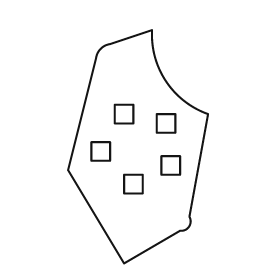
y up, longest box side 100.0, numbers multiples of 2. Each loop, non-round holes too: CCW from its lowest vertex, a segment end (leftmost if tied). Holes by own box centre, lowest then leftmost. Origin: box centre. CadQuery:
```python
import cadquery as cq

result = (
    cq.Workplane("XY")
    .moveTo(-6.0, -50.0)
    .lineTo(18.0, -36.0)
    .threePointArc((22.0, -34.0), (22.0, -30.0))
    .lineTo(30.0, 14.0)
    .threePointArc((12.0, 28.0), (6.0, 50.0))
    .lineTo(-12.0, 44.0)
    .threePointArc((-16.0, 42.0), (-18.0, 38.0))
    .lineTo(-30.0, -10.0)
    .close()
    .moveTo(-6.0, -20.0)
    .lineTo(2.0, -20.0)
    .lineTo(2.0, -12.0)
    .lineTo(-6.0, -12.0)
    .close()
    .moveTo(10.0, -12.0)
    .lineTo(18.0, -12.0)
    .lineTo(18.0, -4.0)
    .lineTo(10.0, -4.0)
    .close()
    .moveTo(-20.0, -6.0)
    .lineTo(-12.0, -6.0)
    .lineTo(-12.0, 2.0)
    .lineTo(-20.0, 2.0)
    .close()
    .moveTo(8.0, 6.0)
    .lineTo(16.0, 6.0)
    .lineTo(16.0, 14.0)
    .lineTo(8.0, 14.0)
    .close()
    .moveTo(-10.0, 10.0)
    .lineTo(-2.0, 10.0)
    .lineTo(-2.0, 18.0)
    .lineTo(-10.0, 18.0)
    .close()
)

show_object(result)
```